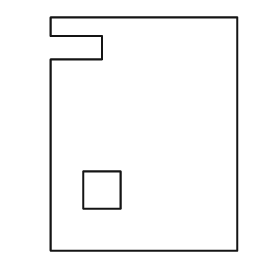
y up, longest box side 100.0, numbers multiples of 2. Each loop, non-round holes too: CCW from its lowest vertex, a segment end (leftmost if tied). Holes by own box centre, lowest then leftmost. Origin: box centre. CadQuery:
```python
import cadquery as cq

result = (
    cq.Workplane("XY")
    .moveTo(-40.0, -50.0)
    .lineTo(40.0, -50.0)
    .lineTo(40.0, 50.0)
    .lineTo(-40.0, 50.0)
    .lineTo(-40.0, 42.0)
    .lineTo(-18.0, 42.0)
    .lineTo(-18.0, 32.0)
    .lineTo(-40.0, 32.0)
    .close()
    .moveTo(-26.0, -32.0)
    .lineTo(-10.0, -32.0)
    .lineTo(-10.0, -16.0)
    .lineTo(-26.0, -16.0)
    .close()
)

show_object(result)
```